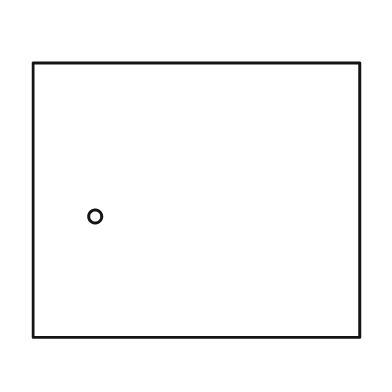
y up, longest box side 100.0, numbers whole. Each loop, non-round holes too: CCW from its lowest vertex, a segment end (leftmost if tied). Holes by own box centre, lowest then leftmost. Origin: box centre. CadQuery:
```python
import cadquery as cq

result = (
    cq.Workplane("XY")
    .moveTo(-50.0, -42.0)
    .lineTo(50.0, -42.0)
    .lineTo(50.0, 42.0)
    .lineTo(-50.0, 42.0)
    .close()
    .moveTo(-31.0, -5.0)
    .circle(2.0)
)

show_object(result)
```